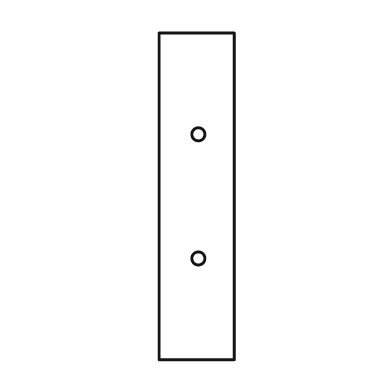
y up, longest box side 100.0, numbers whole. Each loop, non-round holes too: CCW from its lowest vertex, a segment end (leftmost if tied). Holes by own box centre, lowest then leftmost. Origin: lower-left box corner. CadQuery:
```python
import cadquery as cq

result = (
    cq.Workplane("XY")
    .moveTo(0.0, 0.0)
    .lineTo(23.0, 0.0)
    .lineTo(23.0, 100.0)
    .lineTo(0.0, 100.0)
    .close()
    .moveTo(12.0, 31.0)
    .circle(2.0)
    .moveTo(12.0, 69.0)
    .circle(2.0)
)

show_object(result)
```